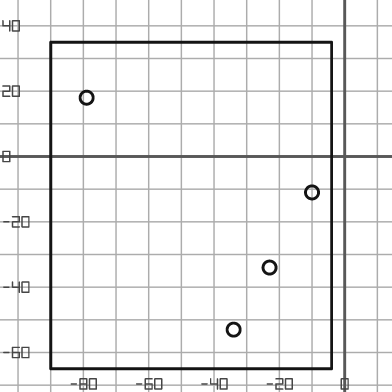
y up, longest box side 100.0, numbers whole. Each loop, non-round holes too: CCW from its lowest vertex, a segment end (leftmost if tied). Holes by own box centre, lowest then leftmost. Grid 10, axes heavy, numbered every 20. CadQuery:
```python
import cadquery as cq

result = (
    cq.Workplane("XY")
    .moveTo(-90.0, -65.0)
    .lineTo(-4.0, -65.0)
    .lineTo(-4.0, 35.0)
    .lineTo(-90.0, 35.0)
    .close()
    .moveTo(-34.0, -53.0)
    .circle(2.0)
    .moveTo(-23.0, -34.0)
    .circle(2.0)
    .moveTo(-10.0, -11.0)
    .circle(2.0)
    .moveTo(-79.0, 18.0)
    .circle(2.0)
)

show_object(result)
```